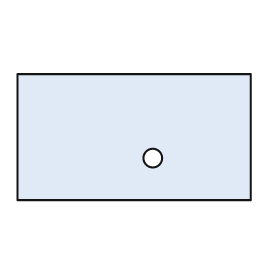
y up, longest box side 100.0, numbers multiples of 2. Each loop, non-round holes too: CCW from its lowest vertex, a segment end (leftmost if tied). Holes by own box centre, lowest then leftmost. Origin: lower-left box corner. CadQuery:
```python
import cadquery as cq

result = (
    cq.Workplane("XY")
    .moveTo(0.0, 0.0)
    .lineTo(100.0, 0.0)
    .lineTo(100.0, 54.0)
    .lineTo(0.0, 54.0)
    .close()
    .moveTo(58.0, 18.0)
    .circle(4.0)
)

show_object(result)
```